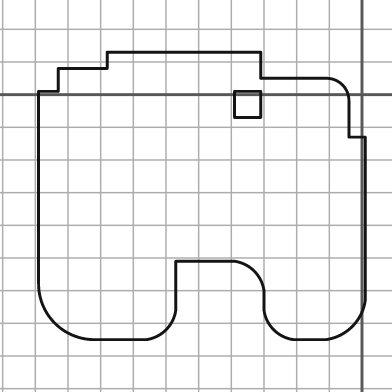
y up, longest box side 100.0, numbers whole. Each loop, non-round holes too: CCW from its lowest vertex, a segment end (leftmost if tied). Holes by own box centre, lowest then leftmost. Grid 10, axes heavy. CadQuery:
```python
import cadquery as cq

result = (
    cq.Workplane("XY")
    .moveTo(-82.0, -75.0)
    .lineTo(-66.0, -75.0)
    .threePointArc((-60.0, -72.0), (-57.0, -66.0))
    .lineTo(-57.0, -51.0)
    .lineTo(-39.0, -51.0)
    .threePointArc((-33.0, -54.0), (-30.0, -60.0))
    .lineTo(-30.0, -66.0)
    .threePointArc((-27.0, -72.0), (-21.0, -75.0))
    .lineTo(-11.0, -75.0)
    .threePointArc((-3.0, -71.0), (1.0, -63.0))
    .lineTo(1.0, -13.0)
    .lineTo(-4.0, -13.0)
    .lineTo(-4.0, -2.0)
    .threePointArc((-6.0, 3.0), (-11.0, 5.0))
    .lineTo(-31.0, 5.0)
    .lineTo(-31.0, 13.0)
    .lineTo(-78.0, 13.0)
    .lineTo(-78.0, 8.0)
    .lineTo(-93.0, 8.0)
    .lineTo(-93.0, 1.0)
    .lineTo(-99.0, 1.0)
    .lineTo(-99.0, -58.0)
    .threePointArc((-94.0, -70.0), (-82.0, -75.0))
    .close()
    .moveTo(-39.0, -7.0)
    .lineTo(-31.0, -7.0)
    .lineTo(-31.0, 1.0)
    .lineTo(-39.0, 1.0)
    .close()
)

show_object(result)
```